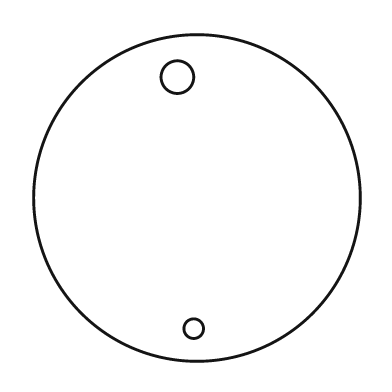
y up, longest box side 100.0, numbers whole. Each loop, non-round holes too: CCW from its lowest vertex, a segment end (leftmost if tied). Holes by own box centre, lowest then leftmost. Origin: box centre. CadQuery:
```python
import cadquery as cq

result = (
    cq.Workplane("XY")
    .moveTo(0.0, 0.0)
    .circle(50.0)
    .moveTo(-1.0, -40.0)
    .circle(3.0)
    .moveTo(-6.0, 37.0)
    .circle(5.0)
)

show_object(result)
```